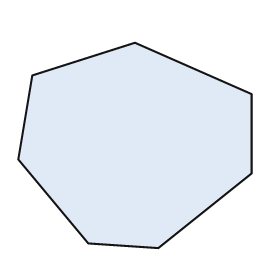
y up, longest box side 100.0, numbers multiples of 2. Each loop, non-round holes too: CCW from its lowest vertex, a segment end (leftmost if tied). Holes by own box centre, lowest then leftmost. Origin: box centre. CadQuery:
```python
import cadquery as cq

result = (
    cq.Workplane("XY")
    .moveTo(10.0, -44.0)
    .lineTo(50.0, -12.0)
    .lineTo(50.0, 22.0)
    .lineTo(0.0, 44.0)
    .lineTo(-44.0, 30.0)
    .lineTo(-50.0, -6.0)
    .lineTo(-20.0, -42.0)
    .close()
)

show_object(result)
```